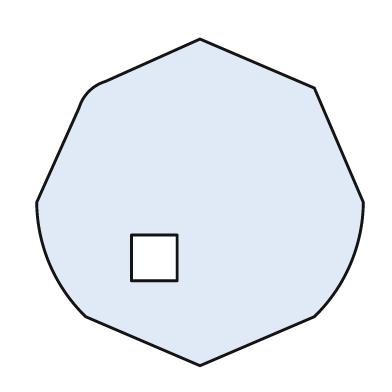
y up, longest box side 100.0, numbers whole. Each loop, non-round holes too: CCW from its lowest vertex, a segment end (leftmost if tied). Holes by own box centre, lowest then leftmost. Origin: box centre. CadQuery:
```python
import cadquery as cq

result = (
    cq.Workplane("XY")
    .moveTo(0.0, -50.0)
    .lineTo(35.0, -35.0)
    .threePointArc((46.0, -19.0), (50.0, 0.0))
    .lineTo(35.0, 35.0)
    .lineTo(0.0, 50.0)
    .lineTo(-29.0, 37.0)
    .threePointArc((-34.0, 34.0), (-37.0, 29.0))
    .lineTo(-50.0, 0.0)
    .threePointArc((-46.0, -19.0), (-35.0, -35.0))
    .close()
    .moveTo(-21.0, -24.0)
    .lineTo(-7.0, -24.0)
    .lineTo(-7.0, -10.0)
    .lineTo(-21.0, -10.0)
    .close()
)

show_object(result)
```